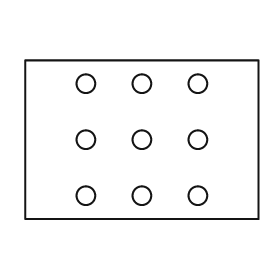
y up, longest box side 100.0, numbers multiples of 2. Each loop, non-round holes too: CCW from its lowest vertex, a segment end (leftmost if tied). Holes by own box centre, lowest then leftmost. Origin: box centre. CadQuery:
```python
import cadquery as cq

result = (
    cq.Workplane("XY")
    .moveTo(-50.0, -34.0)
    .lineTo(50.0, -34.0)
    .lineTo(50.0, 34.0)
    .lineTo(-50.0, 34.0)
    .close()
    .moveTo(-24.0, -24.0)
    .circle(4.0)
    .moveTo(0.0, -24.0)
    .circle(4.0)
    .moveTo(24.0, -24.0)
    .circle(4.0)
    .moveTo(-24.0, 0.0)
    .circle(4.0)
    .moveTo(0.0, 0.0)
    .circle(4.0)
    .moveTo(24.0, 0.0)
    .circle(4.0)
    .moveTo(-24.0, 24.0)
    .circle(4.0)
    .moveTo(0.0, 24.0)
    .circle(4.0)
    .moveTo(24.0, 24.0)
    .circle(4.0)
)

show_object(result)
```